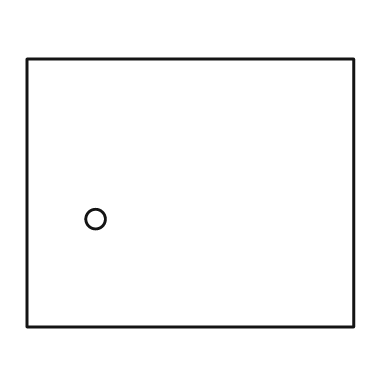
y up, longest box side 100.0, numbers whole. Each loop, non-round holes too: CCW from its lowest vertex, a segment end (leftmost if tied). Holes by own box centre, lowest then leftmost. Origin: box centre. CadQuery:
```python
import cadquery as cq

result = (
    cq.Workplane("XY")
    .moveTo(-50.0, -41.0)
    .lineTo(50.0, -41.0)
    .lineTo(50.0, 41.0)
    .lineTo(-50.0, 41.0)
    .close()
    .moveTo(-29.0, -8.0)
    .circle(3.0)
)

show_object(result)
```